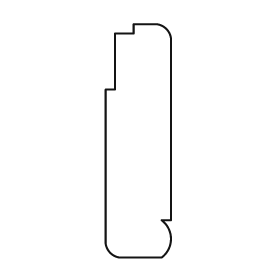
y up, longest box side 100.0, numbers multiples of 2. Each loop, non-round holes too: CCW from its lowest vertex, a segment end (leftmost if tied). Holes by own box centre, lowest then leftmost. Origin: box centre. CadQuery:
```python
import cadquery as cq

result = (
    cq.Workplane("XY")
    .moveTo(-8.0, -50.0)
    .lineTo(10.0, -50.0)
    .threePointArc((14.0, -42.0), (10.0, -34.0))
    .lineTo(14.0, -34.0)
    .lineTo(14.0, 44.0)
    .threePointArc((12.0, 48.0), (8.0, 50.0))
    .lineTo(-2.0, 50.0)
    .lineTo(-2.0, 46.0)
    .lineTo(-10.0, 46.0)
    .lineTo(-10.0, 22.0)
    .lineTo(-14.0, 22.0)
    .lineTo(-14.0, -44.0)
    .threePointArc((-12.0, -48.0), (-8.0, -50.0))
    .close()
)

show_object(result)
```